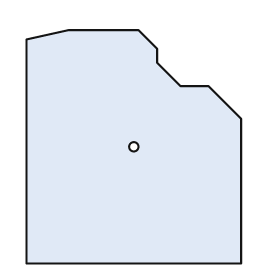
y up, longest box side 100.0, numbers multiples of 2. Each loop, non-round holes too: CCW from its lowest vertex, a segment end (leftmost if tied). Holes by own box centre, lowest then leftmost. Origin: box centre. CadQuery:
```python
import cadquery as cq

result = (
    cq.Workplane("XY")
    .moveTo(-46.0, -50.0)
    .lineTo(46.0, -50.0)
    .lineTo(46.0, 12.0)
    .lineTo(32.0, 26.0)
    .lineTo(20.0, 26.0)
    .lineTo(10.0, 36.0)
    .lineTo(10.0, 42.0)
    .lineTo(2.0, 50.0)
    .lineTo(-28.0, 50.0)
    .lineTo(-46.0, 46.0)
    .close()
    .moveTo(0.0, 0.0)
    .circle(2.0)
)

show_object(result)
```